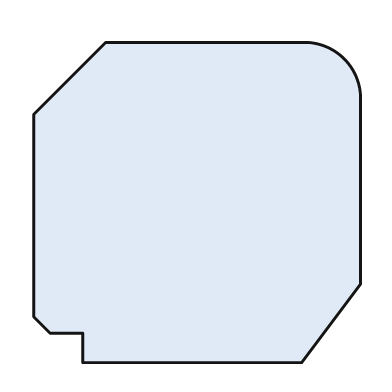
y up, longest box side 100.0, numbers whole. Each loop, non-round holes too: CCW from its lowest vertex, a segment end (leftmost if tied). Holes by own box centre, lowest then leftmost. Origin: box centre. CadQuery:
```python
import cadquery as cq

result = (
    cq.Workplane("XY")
    .moveTo(-35.0, -49.0)
    .lineTo(32.0, -49.0)
    .lineTo(50.0, -25.0)
    .lineTo(50.0, 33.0)
    .threePointArc((45.0, 44.0), (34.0, 49.0))
    .lineTo(-28.0, 49.0)
    .lineTo(-50.0, 27.0)
    .lineTo(-50.0, -35.0)
    .lineTo(-45.0, -40.0)
    .lineTo(-35.0, -40.0)
    .close()
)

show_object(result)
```